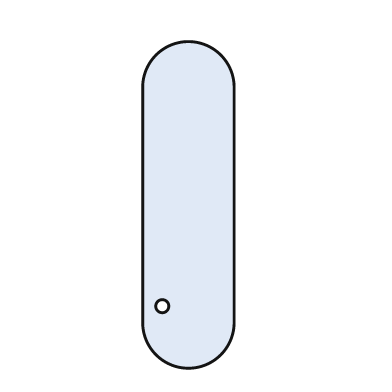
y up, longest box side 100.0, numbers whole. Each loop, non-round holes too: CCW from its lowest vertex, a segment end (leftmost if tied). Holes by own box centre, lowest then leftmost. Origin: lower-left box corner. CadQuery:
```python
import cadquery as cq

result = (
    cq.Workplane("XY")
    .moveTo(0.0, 14.0)
    .threePointArc((14.0, 0.0), (28.0, 14.0))
    .lineTo(28.0, 86.0)
    .threePointArc((14.0, 100.0), (0.0, 86.0))
    .close()
    .moveTo(6.0, 19.0)
    .circle(2.0)
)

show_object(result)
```